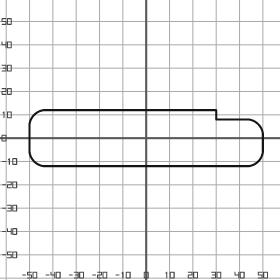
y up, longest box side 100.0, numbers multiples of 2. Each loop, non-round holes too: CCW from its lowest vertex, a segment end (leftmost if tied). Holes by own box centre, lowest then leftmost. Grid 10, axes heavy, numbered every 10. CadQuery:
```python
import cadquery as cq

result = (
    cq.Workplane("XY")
    .moveTo(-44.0, -12.0)
    .lineTo(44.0, -12.0)
    .threePointArc((48.0, -10.0), (50.0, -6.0))
    .lineTo(50.0, 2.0)
    .threePointArc((48.0, 6.0), (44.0, 8.0))
    .lineTo(30.0, 8.0)
    .lineTo(30.0, 12.0)
    .lineTo(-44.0, 12.0)
    .threePointArc((-48.0, 10.0), (-50.0, 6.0))
    .lineTo(-50.0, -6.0)
    .threePointArc((-48.0, -10.0), (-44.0, -12.0))
    .close()
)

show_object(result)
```